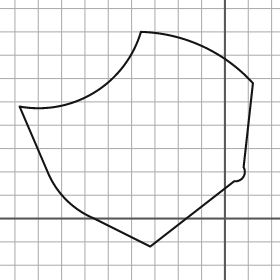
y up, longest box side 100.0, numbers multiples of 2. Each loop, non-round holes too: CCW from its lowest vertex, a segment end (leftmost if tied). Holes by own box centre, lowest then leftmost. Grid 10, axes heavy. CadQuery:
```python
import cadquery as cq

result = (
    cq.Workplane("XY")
    .moveTo(-32.0, -12.0)
    .lineTo(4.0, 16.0)
    .threePointArc((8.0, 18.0), (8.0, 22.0))
    .lineTo(12.0, 58.0)
    .threePointArc((-10.0, 74.0), (-36.0, 80.0))
    .threePointArc((-56.0, 54.0), (-88.0, 48.0))
    .lineTo(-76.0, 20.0)
    .threePointArc((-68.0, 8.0), (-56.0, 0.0))
    .close()
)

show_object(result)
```